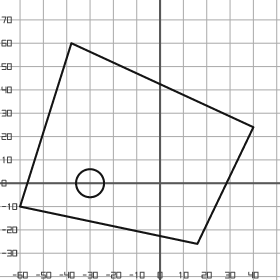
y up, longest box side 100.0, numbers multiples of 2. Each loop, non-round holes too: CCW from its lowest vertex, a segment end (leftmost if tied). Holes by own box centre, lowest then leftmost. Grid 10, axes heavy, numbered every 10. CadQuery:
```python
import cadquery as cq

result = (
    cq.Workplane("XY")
    .moveTo(16.0, -26.0)
    .lineTo(40.0, 24.0)
    .lineTo(-38.0, 60.0)
    .lineTo(-60.0, -10.0)
    .close()
    .moveTo(-30.0, 0.0)
    .circle(6.0)
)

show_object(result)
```